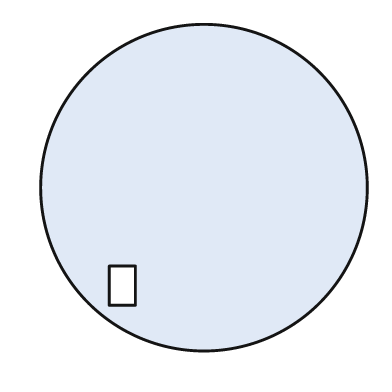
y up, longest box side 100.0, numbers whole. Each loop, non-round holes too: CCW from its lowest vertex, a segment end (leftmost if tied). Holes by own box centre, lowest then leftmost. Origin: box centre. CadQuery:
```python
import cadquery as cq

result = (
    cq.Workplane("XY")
    .moveTo(0.0, 0.0)
    .circle(50.0)
    .moveTo(-29.0, -36.0)
    .lineTo(-21.0, -36.0)
    .lineTo(-21.0, -24.0)
    .lineTo(-29.0, -24.0)
    .close()
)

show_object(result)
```